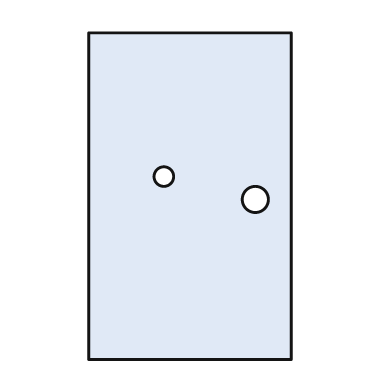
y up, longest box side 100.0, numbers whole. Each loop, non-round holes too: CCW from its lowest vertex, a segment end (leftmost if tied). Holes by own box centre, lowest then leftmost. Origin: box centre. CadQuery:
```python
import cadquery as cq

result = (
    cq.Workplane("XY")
    .moveTo(-31.0, -50.0)
    .lineTo(31.0, -50.0)
    .lineTo(31.0, 50.0)
    .lineTo(-31.0, 50.0)
    .close()
    .moveTo(20.0, -1.0)
    .circle(4.0)
    .moveTo(-8.0, 6.0)
    .circle(3.0)
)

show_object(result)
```